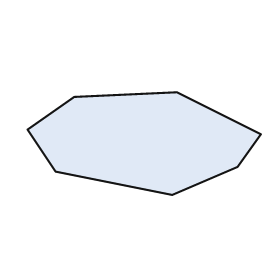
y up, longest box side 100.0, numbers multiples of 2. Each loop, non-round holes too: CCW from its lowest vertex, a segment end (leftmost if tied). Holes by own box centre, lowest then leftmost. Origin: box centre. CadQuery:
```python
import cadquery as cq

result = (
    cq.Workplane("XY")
    .moveTo(12.0, -22.0)
    .lineTo(40.0, -10.0)
    .lineTo(50.0, 4.0)
    .lineTo(14.0, 22.0)
    .lineTo(-30.0, 20.0)
    .lineTo(-50.0, 6.0)
    .lineTo(-38.0, -12.0)
    .close()
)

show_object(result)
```